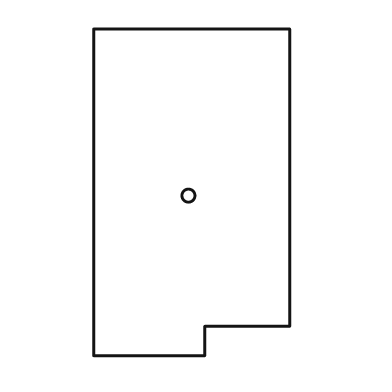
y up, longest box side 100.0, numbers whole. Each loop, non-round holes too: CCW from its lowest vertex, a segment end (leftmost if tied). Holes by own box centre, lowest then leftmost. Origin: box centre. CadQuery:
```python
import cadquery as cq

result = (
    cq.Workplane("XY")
    .moveTo(-30.0, -50.0)
    .lineTo(4.0, -50.0)
    .lineTo(4.0, -41.0)
    .lineTo(30.0, -41.0)
    .lineTo(30.0, 50.0)
    .lineTo(-30.0, 50.0)
    .close()
    .moveTo(-1.0, -1.0)
    .circle(2.0)
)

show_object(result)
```